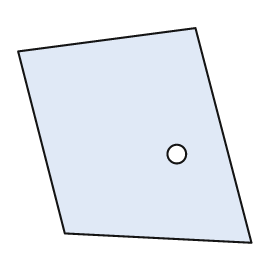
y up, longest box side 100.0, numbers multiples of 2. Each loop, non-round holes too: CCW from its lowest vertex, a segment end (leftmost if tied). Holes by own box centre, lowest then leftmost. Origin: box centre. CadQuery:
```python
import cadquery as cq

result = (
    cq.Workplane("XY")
    .moveTo(50.0, -46.0)
    .lineTo(26.0, 46.0)
    .lineTo(-50.0, 36.0)
    .lineTo(-30.0, -42.0)
    .close()
    .moveTo(18.0, -8.0)
    .circle(4.0)
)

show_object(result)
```